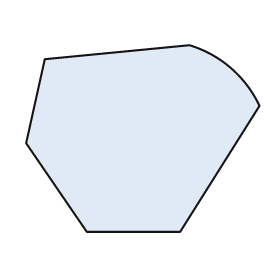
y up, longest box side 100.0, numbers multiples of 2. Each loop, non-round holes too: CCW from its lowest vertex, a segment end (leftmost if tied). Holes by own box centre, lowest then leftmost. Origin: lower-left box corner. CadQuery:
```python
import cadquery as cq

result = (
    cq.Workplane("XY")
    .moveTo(26.0, 0.0)
    .lineTo(66.0, 0.0)
    .lineTo(100.0, 54.0)
    .threePointArc((88.0, 70.0), (70.0, 80.0))
    .lineTo(8.0, 74.0)
    .lineTo(0.0, 38.0)
    .close()
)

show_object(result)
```